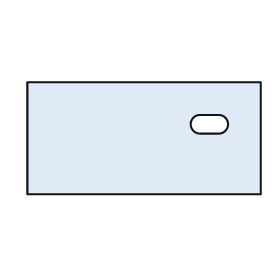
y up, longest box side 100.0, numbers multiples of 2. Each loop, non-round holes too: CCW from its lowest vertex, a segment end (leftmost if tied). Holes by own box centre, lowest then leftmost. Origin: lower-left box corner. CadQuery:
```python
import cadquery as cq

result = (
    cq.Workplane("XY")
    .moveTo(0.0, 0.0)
    .lineTo(100.0, 0.0)
    .lineTo(100.0, 48.0)
    .lineTo(0.0, 48.0)
    .close()
    .moveTo(74.0, 26.0)
    .lineTo(82.0, 26.0)
    .threePointArc((86.0, 30.0), (82.0, 34.0))
    .lineTo(74.0, 34.0)
    .threePointArc((70.0, 30.0), (74.0, 26.0))
    .close()
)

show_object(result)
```